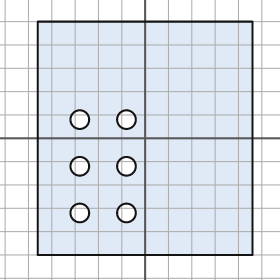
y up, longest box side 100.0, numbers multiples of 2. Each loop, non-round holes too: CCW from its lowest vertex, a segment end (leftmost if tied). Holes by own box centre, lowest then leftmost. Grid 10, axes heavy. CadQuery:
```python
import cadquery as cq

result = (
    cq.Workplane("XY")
    .moveTo(-46.0, -50.0)
    .lineTo(46.0, -50.0)
    .lineTo(46.0, 50.0)
    .lineTo(-46.0, 50.0)
    .close()
    .moveTo(-28.0, -32.0)
    .circle(4.0)
    .moveTo(-8.0, -32.0)
    .circle(4.0)
    .moveTo(-28.0, -12.0)
    .circle(4.0)
    .moveTo(-8.0, -12.0)
    .circle(4.0)
    .moveTo(-28.0, 8.0)
    .circle(4.0)
    .moveTo(-8.0, 8.0)
    .circle(4.0)
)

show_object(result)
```